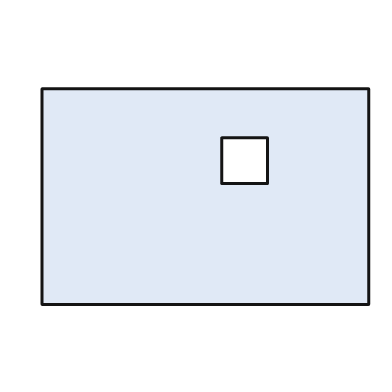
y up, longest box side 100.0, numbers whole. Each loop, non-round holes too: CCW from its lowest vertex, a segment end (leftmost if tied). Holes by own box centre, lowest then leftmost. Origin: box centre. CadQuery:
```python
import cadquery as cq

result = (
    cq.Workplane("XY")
    .moveTo(-50.0, -33.0)
    .lineTo(50.0, -33.0)
    .lineTo(50.0, 33.0)
    .lineTo(-50.0, 33.0)
    .close()
    .moveTo(5.0, 4.0)
    .lineTo(19.0, 4.0)
    .lineTo(19.0, 18.0)
    .lineTo(5.0, 18.0)
    .close()
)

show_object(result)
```